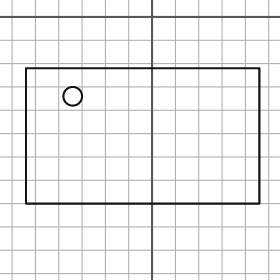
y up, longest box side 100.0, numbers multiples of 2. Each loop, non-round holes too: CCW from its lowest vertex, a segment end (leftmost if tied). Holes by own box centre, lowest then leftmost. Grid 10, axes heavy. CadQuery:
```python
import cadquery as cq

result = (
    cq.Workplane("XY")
    .moveTo(-54.0, -80.0)
    .lineTo(46.0, -80.0)
    .lineTo(46.0, -22.0)
    .lineTo(-54.0, -22.0)
    .close()
    .moveTo(-34.0, -34.0)
    .circle(4.0)
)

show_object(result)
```